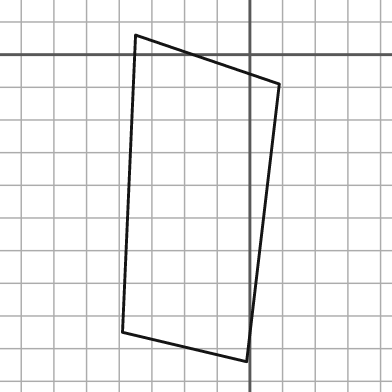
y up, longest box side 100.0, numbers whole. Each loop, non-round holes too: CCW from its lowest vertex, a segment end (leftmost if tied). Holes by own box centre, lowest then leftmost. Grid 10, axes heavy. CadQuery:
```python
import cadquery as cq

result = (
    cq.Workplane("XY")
    .moveTo(-1.0, -94.0)
    .lineTo(9.0, -9.0)
    .lineTo(-35.0, 6.0)
    .lineTo(-39.0, -85.0)
    .close()
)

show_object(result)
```